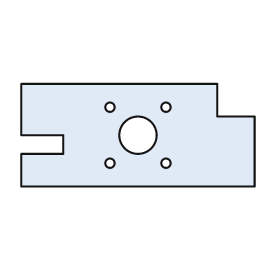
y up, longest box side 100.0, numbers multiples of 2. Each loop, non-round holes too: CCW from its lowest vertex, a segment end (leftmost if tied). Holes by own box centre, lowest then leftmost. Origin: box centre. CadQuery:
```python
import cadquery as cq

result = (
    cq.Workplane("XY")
    .moveTo(-50.0, -22.0)
    .lineTo(50.0, -22.0)
    .lineTo(50.0, 8.0)
    .lineTo(34.0, 8.0)
    .lineTo(34.0, 22.0)
    .lineTo(-50.0, 22.0)
    .lineTo(-50.0, 0.0)
    .lineTo(-32.0, 0.0)
    .lineTo(-32.0, -8.0)
    .lineTo(-50.0, -8.0)
    .close()
    .moveTo(-12.0, -12.0)
    .circle(2.0)
    .moveTo(12.0, -12.0)
    .circle(2.0)
    .moveTo(0.0, 0.0)
    .circle(8.0)
    .moveTo(-12.0, 12.0)
    .circle(2.0)
    .moveTo(12.0, 12.0)
    .circle(2.0)
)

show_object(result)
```